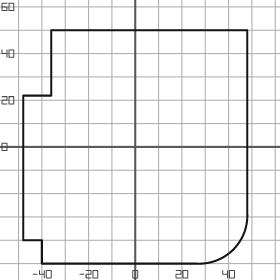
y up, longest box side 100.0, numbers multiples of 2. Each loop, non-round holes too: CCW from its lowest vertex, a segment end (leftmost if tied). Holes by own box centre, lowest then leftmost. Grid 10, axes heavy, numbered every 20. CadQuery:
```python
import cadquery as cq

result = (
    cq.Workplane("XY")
    .moveTo(-40.0, -50.0)
    .lineTo(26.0, -50.0)
    .threePointArc((42.0, -44.0), (48.0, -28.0))
    .lineTo(48.0, 50.0)
    .lineTo(-36.0, 50.0)
    .lineTo(-36.0, 22.0)
    .lineTo(-48.0, 22.0)
    .lineTo(-48.0, -40.0)
    .lineTo(-40.0, -40.0)
    .close()
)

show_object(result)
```